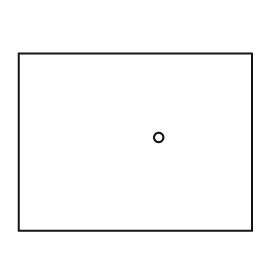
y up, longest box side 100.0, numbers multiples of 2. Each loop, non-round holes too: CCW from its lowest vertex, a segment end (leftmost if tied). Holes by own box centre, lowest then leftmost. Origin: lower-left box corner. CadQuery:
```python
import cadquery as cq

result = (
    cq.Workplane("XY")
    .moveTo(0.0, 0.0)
    .lineTo(100.0, 0.0)
    .lineTo(100.0, 76.0)
    .lineTo(0.0, 76.0)
    .close()
    .moveTo(60.0, 40.0)
    .circle(2.0)
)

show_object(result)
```